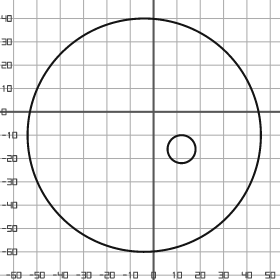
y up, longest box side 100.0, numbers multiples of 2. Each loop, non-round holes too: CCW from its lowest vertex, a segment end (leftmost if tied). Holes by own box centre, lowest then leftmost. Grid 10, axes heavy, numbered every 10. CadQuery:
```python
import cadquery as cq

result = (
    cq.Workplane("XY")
    .moveTo(-4.0, -10.0)
    .circle(50.0)
    .moveTo(12.0, -16.0)
    .circle(6.0)
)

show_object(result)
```